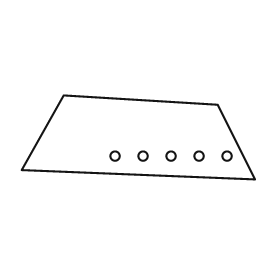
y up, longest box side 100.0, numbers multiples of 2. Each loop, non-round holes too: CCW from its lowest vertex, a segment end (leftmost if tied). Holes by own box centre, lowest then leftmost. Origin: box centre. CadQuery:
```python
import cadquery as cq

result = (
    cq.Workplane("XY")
    .moveTo(50.0, -18.0)
    .lineTo(34.0, 14.0)
    .lineTo(-32.0, 18.0)
    .lineTo(-50.0, -14.0)
    .close()
    .moveTo(-10.0, -8.0)
    .circle(2.0)
    .moveTo(2.0, -8.0)
    .circle(2.0)
    .moveTo(14.0, -8.0)
    .circle(2.0)
    .moveTo(26.0, -8.0)
    .circle(2.0)
    .moveTo(38.0, -8.0)
    .circle(2.0)
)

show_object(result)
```